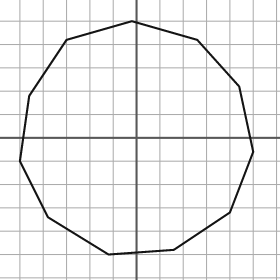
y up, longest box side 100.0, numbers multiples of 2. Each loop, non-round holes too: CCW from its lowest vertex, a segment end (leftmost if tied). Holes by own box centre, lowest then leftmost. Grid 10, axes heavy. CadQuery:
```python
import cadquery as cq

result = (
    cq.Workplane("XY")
    .moveTo(-12.0, -50.0)
    .lineTo(16.0, -48.0)
    .lineTo(40.0, -32.0)
    .lineTo(50.0, -6.0)
    .lineTo(44.0, 22.0)
    .lineTo(26.0, 42.0)
    .lineTo(-2.0, 50.0)
    .lineTo(-30.0, 42.0)
    .lineTo(-46.0, 18.0)
    .lineTo(-50.0, -10.0)
    .lineTo(-38.0, -34.0)
    .close()
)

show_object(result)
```